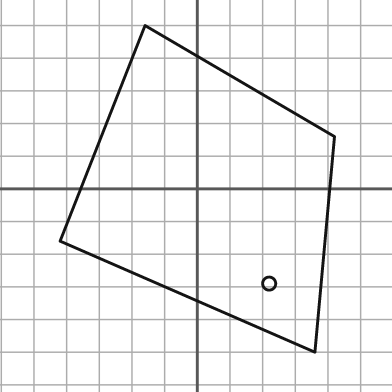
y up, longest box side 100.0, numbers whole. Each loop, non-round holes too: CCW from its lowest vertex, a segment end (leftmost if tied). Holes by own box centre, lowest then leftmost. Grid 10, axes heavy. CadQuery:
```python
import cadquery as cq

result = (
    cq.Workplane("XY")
    .moveTo(36.0, -50.0)
    .lineTo(42.0, 16.0)
    .lineTo(-16.0, 50.0)
    .lineTo(-42.0, -16.0)
    .close()
    .moveTo(22.0, -29.0)
    .circle(2.0)
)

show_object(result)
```